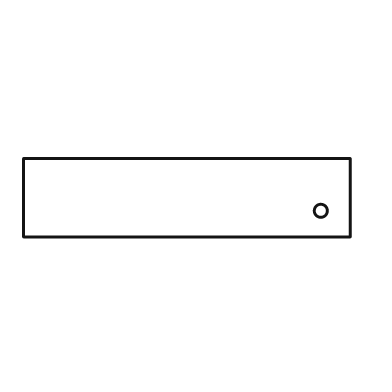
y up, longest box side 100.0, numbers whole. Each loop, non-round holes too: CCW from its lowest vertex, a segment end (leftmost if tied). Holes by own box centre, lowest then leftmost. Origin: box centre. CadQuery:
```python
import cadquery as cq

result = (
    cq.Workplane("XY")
    .moveTo(-50.0, -12.0)
    .lineTo(50.0, -12.0)
    .lineTo(50.0, 12.0)
    .lineTo(-50.0, 12.0)
    .close()
    .moveTo(41.0, -4.0)
    .circle(2.0)
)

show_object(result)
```